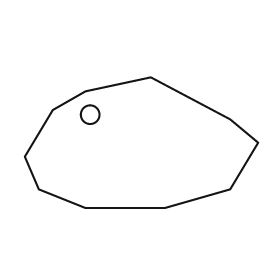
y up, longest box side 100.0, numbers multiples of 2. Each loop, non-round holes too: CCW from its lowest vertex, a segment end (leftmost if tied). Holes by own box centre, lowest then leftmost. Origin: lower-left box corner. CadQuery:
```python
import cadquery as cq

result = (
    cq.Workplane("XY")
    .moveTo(26.0, 0.0)
    .lineTo(60.0, 0.0)
    .lineTo(88.0, 8.0)
    .lineTo(100.0, 28.0)
    .lineTo(88.0, 38.0)
    .lineTo(54.0, 56.0)
    .lineTo(26.0, 50.0)
    .lineTo(12.0, 42.0)
    .lineTo(0.0, 22.0)
    .lineTo(6.0, 8.0)
    .close()
    .moveTo(28.0, 40.0)
    .circle(4.0)
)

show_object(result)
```